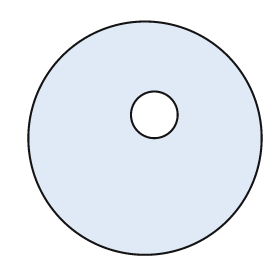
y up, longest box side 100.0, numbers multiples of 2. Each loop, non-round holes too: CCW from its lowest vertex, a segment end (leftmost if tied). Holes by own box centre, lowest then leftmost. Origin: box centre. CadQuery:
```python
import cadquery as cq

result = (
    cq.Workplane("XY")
    .moveTo(0.0, 0.0)
    .circle(50.0)
    .moveTo(4.0, 10.0)
    .circle(10.0)
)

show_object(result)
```